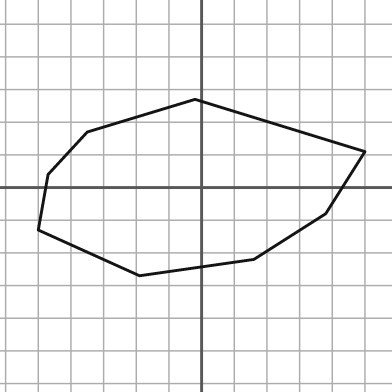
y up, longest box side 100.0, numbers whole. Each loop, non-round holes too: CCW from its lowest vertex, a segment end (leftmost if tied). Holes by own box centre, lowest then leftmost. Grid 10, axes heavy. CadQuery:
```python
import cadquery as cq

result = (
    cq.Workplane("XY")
    .moveTo(-19.0, -27.0)
    .lineTo(16.0, -22.0)
    .lineTo(38.0, -8.0)
    .lineTo(50.0, 11.0)
    .lineTo(-2.0, 27.0)
    .lineTo(-35.0, 17.0)
    .lineTo(-47.0, 4.0)
    .lineTo(-50.0, -13.0)
    .close()
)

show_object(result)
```